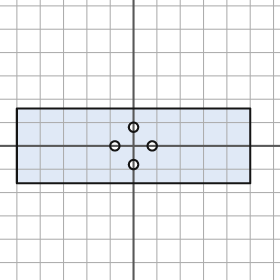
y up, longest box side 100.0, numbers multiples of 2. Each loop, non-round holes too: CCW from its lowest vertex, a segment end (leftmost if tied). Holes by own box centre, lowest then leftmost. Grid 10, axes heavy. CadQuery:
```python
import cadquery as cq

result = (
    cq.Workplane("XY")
    .moveTo(-50.0, -16.0)
    .lineTo(50.0, -16.0)
    .lineTo(50.0, 16.0)
    .lineTo(-50.0, 16.0)
    .close()
    .moveTo(0.0, -8.0)
    .circle(2.0)
    .moveTo(-8.0, 0.0)
    .circle(2.0)
    .moveTo(8.0, 0.0)
    .circle(2.0)
    .moveTo(0.0, 8.0)
    .circle(2.0)
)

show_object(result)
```